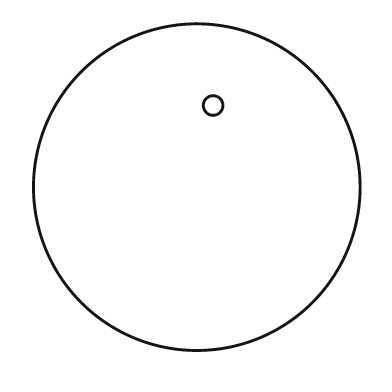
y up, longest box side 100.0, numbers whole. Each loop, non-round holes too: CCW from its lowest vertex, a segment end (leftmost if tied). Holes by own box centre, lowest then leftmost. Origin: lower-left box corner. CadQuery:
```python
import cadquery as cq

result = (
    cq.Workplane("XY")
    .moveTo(50.0, 50.0)
    .circle(50.0)
    .moveTo(55.0, 75.0)
    .circle(3.0)
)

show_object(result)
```